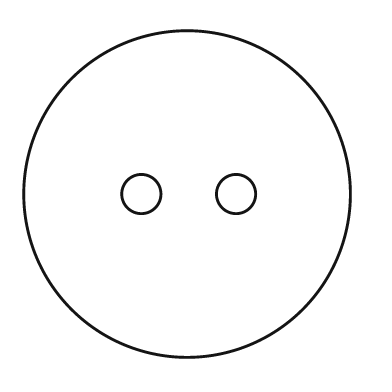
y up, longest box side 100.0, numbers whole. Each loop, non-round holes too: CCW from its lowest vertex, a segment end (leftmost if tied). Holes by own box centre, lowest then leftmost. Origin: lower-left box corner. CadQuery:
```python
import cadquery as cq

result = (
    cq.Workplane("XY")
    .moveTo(50.0, 50.0)
    .circle(50.0)
    .moveTo(36.0, 50.0)
    .circle(6.0)
    .moveTo(65.0, 50.0)
    .circle(6.0)
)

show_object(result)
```